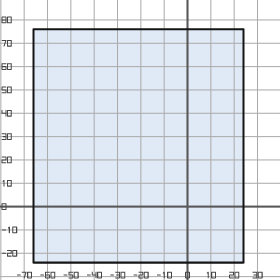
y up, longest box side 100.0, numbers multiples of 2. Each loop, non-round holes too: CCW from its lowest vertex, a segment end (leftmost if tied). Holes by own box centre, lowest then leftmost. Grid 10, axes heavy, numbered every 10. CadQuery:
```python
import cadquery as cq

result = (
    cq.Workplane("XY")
    .moveTo(-66.0, -24.0)
    .lineTo(24.0, -24.0)
    .lineTo(24.0, 76.0)
    .lineTo(-66.0, 76.0)
    .close()
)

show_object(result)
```